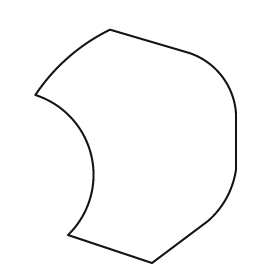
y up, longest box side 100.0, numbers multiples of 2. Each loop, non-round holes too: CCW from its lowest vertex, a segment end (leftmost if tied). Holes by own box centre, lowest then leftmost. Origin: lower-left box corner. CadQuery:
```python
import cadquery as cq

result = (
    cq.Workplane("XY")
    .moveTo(50.0, 0.0)
    .lineTo(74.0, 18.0)
    .threePointArc((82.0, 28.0), (86.0, 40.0))
    .lineTo(86.0, 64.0)
    .threePointArc((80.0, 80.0), (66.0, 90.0))
    .lineTo(32.0, 100.0)
    .threePointArc((14.0, 88.0), (0.0, 72.0))
    .threePointArc((24.0, 46.0), (14.0, 12.0))
    .close()
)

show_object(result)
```